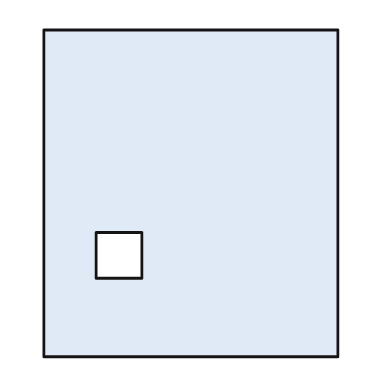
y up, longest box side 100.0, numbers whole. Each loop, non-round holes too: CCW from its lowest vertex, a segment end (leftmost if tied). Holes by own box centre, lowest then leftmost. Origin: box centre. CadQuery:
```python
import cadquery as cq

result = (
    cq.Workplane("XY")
    .moveTo(-45.0, -50.0)
    .lineTo(45.0, -50.0)
    .lineTo(45.0, 50.0)
    .lineTo(-45.0, 50.0)
    .close()
    .moveTo(-29.0, -26.0)
    .lineTo(-15.0, -26.0)
    .lineTo(-15.0, -12.0)
    .lineTo(-29.0, -12.0)
    .close()
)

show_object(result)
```